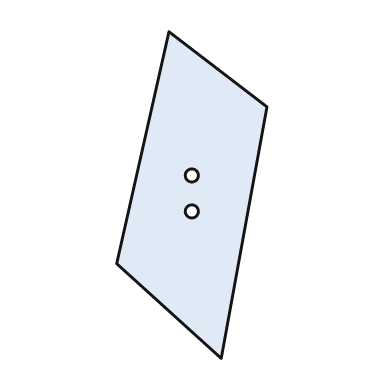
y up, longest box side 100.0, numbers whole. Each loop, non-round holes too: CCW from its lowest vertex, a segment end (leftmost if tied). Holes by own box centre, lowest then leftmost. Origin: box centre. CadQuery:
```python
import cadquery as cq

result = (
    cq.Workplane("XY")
    .moveTo(9.0, -50.0)
    .lineTo(23.0, 27.0)
    .lineTo(-7.0, 50.0)
    .lineTo(-23.0, -21.0)
    .close()
    .moveTo(0.0, -5.0)
    .circle(2.0)
    .moveTo(0.0, 6.0)
    .circle(2.0)
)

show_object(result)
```